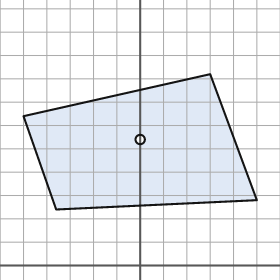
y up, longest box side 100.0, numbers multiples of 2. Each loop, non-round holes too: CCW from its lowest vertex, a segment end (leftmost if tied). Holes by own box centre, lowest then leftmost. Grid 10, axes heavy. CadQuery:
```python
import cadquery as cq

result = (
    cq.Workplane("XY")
    .moveTo(-36.0, 24.0)
    .lineTo(50.0, 28.0)
    .lineTo(30.0, 82.0)
    .lineTo(-50.0, 64.0)
    .close()
    .moveTo(0.0, 54.0)
    .circle(2.0)
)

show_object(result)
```